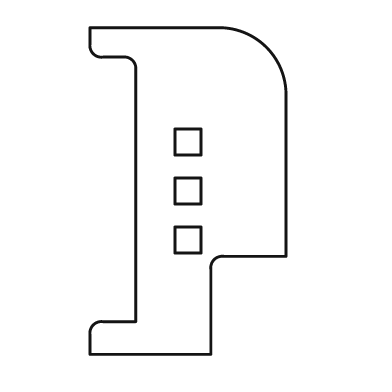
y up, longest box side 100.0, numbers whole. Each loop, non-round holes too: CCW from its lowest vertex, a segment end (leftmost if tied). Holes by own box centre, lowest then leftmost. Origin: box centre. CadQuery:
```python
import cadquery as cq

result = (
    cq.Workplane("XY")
    .moveTo(-30.0, -50.0)
    .lineTo(7.0, -50.0)
    .lineTo(7.0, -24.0)
    .threePointArc((8.0, -21.0), (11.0, -20.0))
    .lineTo(30.0, -20.0)
    .lineTo(30.0, 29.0)
    .threePointArc((24.0, 44.0), (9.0, 50.0))
    .lineTo(-30.0, 50.0)
    .lineTo(-30.0, 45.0)
    .threePointArc((-29.0, 42.0), (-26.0, 41.0))
    .lineTo(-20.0, 41.0)
    .threePointArc((-17.0, 40.0), (-16.0, 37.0))
    .lineTo(-16.0, -40.0)
    .lineTo(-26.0, -40.0)
    .threePointArc((-29.0, -41.0), (-30.0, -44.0))
    .close()
    .moveTo(-4.0, -19.0)
    .lineTo(4.0, -19.0)
    .lineTo(4.0, -11.0)
    .lineTo(-4.0, -11.0)
    .close()
    .moveTo(-4.0, -4.0)
    .lineTo(4.0, -4.0)
    .lineTo(4.0, 4.0)
    .lineTo(-4.0, 4.0)
    .close()
    .moveTo(-4.0, 11.0)
    .lineTo(4.0, 11.0)
    .lineTo(4.0, 19.0)
    .lineTo(-4.0, 19.0)
    .close()
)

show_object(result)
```